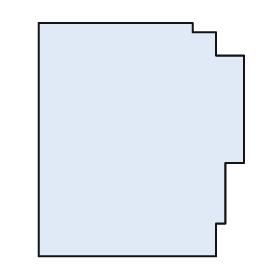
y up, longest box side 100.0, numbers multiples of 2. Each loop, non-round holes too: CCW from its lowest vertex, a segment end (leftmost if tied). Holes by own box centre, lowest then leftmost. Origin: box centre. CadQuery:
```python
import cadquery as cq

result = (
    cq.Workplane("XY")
    .moveTo(-44.0, -50.0)
    .lineTo(32.0, -50.0)
    .lineTo(32.0, -36.0)
    .lineTo(36.0, -36.0)
    .lineTo(36.0, -10.0)
    .lineTo(44.0, -10.0)
    .lineTo(44.0, 36.0)
    .lineTo(32.0, 36.0)
    .lineTo(32.0, 46.0)
    .lineTo(22.0, 46.0)
    .lineTo(22.0, 50.0)
    .lineTo(-44.0, 50.0)
    .close()
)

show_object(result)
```